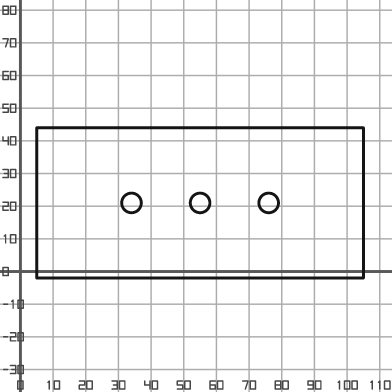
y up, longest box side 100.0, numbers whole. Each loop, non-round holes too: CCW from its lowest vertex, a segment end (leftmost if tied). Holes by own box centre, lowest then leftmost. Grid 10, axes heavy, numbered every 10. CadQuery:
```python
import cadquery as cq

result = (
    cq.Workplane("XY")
    .moveTo(5.0, -2.0)
    .lineTo(105.0, -2.0)
    .lineTo(105.0, 44.0)
    .lineTo(5.0, 44.0)
    .close()
    .moveTo(34.0, 21.0)
    .circle(3.0)
    .moveTo(55.0, 21.0)
    .circle(3.0)
    .moveTo(76.0, 21.0)
    .circle(3.0)
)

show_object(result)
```